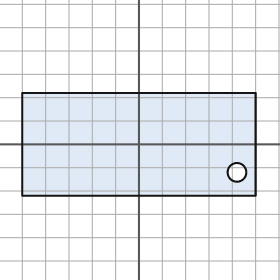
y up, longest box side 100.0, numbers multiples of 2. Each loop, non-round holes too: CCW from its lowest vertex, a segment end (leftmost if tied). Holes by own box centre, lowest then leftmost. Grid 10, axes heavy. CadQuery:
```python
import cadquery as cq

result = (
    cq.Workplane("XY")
    .moveTo(-50.0, -22.0)
    .lineTo(50.0, -22.0)
    .lineTo(50.0, 22.0)
    .lineTo(-50.0, 22.0)
    .close()
    .moveTo(42.0, -12.0)
    .circle(4.0)
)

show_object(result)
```